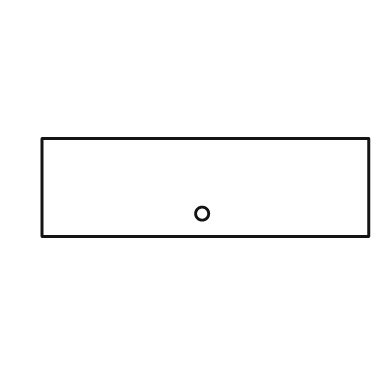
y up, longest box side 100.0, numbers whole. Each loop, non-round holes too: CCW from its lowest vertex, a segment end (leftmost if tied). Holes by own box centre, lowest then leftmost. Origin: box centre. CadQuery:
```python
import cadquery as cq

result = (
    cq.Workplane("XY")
    .moveTo(-50.0, -15.0)
    .lineTo(50.0, -15.0)
    .lineTo(50.0, 15.0)
    .lineTo(-50.0, 15.0)
    .close()
    .moveTo(-1.0, -8.0)
    .circle(2.0)
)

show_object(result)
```